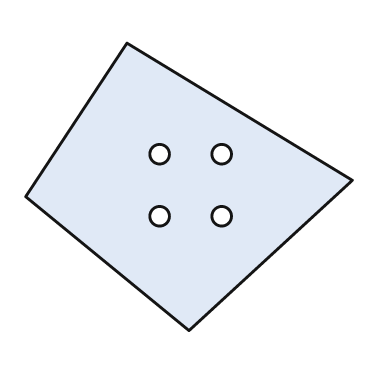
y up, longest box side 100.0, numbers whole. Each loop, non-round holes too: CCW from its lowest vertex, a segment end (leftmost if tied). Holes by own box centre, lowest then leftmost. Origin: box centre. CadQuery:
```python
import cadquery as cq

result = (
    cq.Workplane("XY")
    .moveTo(0.0, -44.0)
    .lineTo(50.0, 2.0)
    .lineTo(-19.0, 44.0)
    .lineTo(-50.0, -3.0)
    .close()
    .moveTo(-9.0, -9.0)
    .circle(3.0)
    .moveTo(10.0, -9.0)
    .circle(3.0)
    .moveTo(-9.0, 10.0)
    .circle(3.0)
    .moveTo(10.0, 10.0)
    .circle(3.0)
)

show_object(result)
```